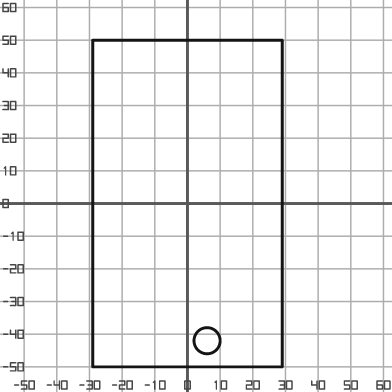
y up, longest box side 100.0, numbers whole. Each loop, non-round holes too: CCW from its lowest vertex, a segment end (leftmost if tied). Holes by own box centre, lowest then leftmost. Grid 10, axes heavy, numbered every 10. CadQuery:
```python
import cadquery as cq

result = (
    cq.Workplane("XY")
    .moveTo(-29.0, -50.0)
    .lineTo(29.0, -50.0)
    .lineTo(29.0, 50.0)
    .lineTo(-29.0, 50.0)
    .close()
    .moveTo(6.0, -42.0)
    .circle(4.0)
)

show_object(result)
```